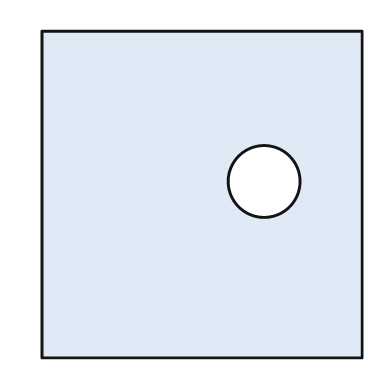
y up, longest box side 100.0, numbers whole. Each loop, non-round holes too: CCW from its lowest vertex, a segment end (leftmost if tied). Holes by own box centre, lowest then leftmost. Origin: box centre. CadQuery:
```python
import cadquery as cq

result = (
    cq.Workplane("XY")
    .moveTo(-49.0, -50.0)
    .lineTo(49.0, -50.0)
    .lineTo(49.0, 50.0)
    .lineTo(-49.0, 50.0)
    .close()
    .moveTo(19.0, 4.0)
    .circle(11.0)
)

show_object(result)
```